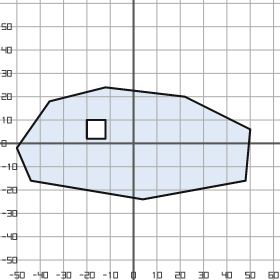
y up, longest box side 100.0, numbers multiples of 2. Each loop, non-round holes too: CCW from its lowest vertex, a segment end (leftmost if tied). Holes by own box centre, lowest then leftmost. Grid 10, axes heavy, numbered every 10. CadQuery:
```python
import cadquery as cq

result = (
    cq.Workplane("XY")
    .moveTo(4.0, -24.0)
    .lineTo(48.0, -16.0)
    .lineTo(50.0, 6.0)
    .lineTo(22.0, 20.0)
    .lineTo(-12.0, 24.0)
    .lineTo(-36.0, 18.0)
    .lineTo(-50.0, -2.0)
    .lineTo(-44.0, -16.0)
    .close()
    .moveTo(-20.0, 2.0)
    .lineTo(-12.0, 2.0)
    .lineTo(-12.0, 10.0)
    .lineTo(-20.0, 10.0)
    .close()
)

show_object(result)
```